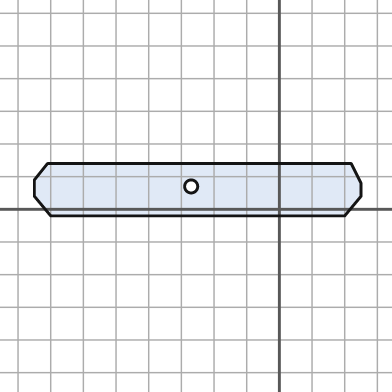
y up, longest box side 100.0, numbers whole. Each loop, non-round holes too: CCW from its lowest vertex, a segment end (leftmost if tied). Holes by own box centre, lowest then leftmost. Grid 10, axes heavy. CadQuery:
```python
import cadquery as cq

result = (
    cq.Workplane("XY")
    .moveTo(-70.0, -2.0)
    .lineTo(20.0, -2.0)
    .lineTo(25.0, 4.0)
    .lineTo(25.0, 8.0)
    .lineTo(22.0, 14.0)
    .lineTo(-71.0, 14.0)
    .lineTo(-75.0, 9.0)
    .lineTo(-75.0, 4.0)
    .close()
    .moveTo(-27.0, 7.0)
    .circle(2.0)
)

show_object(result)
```